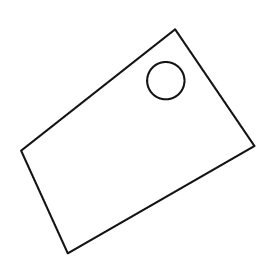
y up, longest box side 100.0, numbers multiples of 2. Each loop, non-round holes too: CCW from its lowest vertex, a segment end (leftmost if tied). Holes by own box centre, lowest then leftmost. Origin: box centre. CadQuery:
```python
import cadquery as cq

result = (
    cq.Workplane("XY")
    .moveTo(-30.0, -48.0)
    .lineTo(50.0, -2.0)
    .lineTo(16.0, 48.0)
    .lineTo(-50.0, -4.0)
    .close()
    .moveTo(12.0, 26.0)
    .circle(8.0)
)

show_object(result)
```